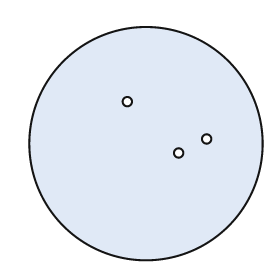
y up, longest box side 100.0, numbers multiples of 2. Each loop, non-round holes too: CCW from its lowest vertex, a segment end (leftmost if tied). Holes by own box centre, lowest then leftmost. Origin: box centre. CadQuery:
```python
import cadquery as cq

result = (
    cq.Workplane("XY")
    .moveTo(0.0, 0.0)
    .circle(50.0)
    .moveTo(14.0, -4.0)
    .circle(2.0)
    .moveTo(26.0, 2.0)
    .circle(2.0)
    .moveTo(-8.0, 18.0)
    .circle(2.0)
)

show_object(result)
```